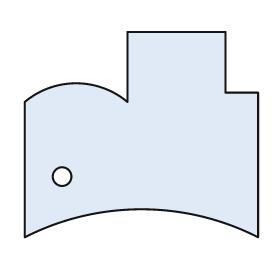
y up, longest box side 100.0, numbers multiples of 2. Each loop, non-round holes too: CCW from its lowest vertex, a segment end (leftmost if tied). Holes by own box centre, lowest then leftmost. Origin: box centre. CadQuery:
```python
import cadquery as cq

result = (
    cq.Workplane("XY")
    .moveTo(-50.0, -44.0)
    .threePointArc((0.0, -32.0), (50.0, -44.0))
    .lineTo(50.0, 18.0)
    .lineTo(36.0, 18.0)
    .lineTo(36.0, 44.0)
    .lineTo(-6.0, 44.0)
    .lineTo(-6.0, 14.0)
    .threePointArc((-28.0, 22.0), (-50.0, 14.0))
    .close()
    .moveTo(-34.0, -18.0)
    .circle(4.0)
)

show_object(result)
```